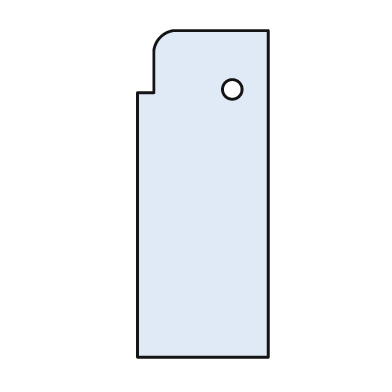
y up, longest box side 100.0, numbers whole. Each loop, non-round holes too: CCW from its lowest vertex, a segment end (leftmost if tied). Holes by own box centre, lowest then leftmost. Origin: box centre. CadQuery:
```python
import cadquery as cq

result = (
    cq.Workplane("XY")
    .moveTo(-20.0, -50.0)
    .lineTo(20.0, -50.0)
    .lineTo(20.0, 50.0)
    .lineTo(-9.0, 50.0)
    .threePointArc((-13.0, 48.0), (-15.0, 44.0))
    .lineTo(-15.0, 31.0)
    .lineTo(-20.0, 31.0)
    .close()
    .moveTo(9.0, 32.0)
    .circle(3.0)
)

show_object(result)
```